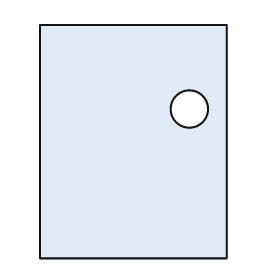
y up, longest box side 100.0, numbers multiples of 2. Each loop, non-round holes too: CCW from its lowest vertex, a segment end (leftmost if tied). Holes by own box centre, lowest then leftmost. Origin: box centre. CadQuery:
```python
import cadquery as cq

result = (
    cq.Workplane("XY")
    .moveTo(-40.0, -50.0)
    .lineTo(40.0, -50.0)
    .lineTo(40.0, 50.0)
    .lineTo(-40.0, 50.0)
    .close()
    .moveTo(24.0, 14.0)
    .circle(8.0)
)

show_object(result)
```